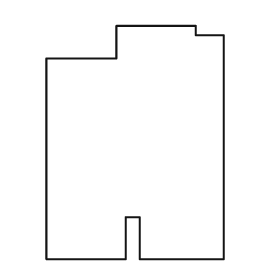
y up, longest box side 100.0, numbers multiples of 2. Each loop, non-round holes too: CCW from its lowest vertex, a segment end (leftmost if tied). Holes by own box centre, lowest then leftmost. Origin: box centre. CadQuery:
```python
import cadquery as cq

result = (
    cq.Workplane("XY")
    .moveTo(-38.0, -50.0)
    .lineTo(-4.0, -50.0)
    .lineTo(-4.0, -32.0)
    .lineTo(2.0, -32.0)
    .lineTo(2.0, -50.0)
    .lineTo(38.0, -50.0)
    .lineTo(38.0, 46.0)
    .lineTo(26.0, 46.0)
    .lineTo(26.0, 50.0)
    .lineTo(-8.0, 50.0)
    .lineTo(-8.0, 36.0)
    .lineTo(-38.0, 36.0)
    .close()
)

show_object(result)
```